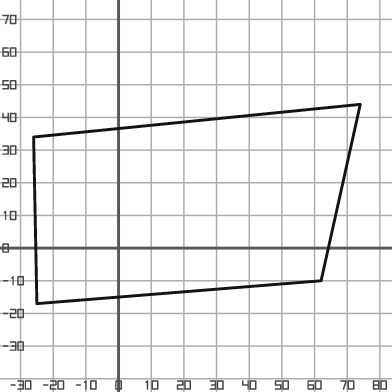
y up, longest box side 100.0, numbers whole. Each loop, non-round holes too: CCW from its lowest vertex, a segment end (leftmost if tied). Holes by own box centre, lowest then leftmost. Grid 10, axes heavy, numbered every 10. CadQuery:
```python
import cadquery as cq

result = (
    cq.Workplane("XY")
    .moveTo(-25.0, -17.0)
    .lineTo(62.0, -10.0)
    .lineTo(74.0, 44.0)
    .lineTo(-26.0, 34.0)
    .close()
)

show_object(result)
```